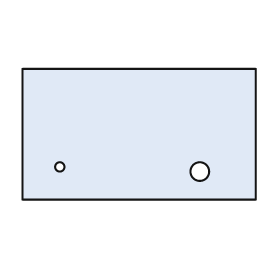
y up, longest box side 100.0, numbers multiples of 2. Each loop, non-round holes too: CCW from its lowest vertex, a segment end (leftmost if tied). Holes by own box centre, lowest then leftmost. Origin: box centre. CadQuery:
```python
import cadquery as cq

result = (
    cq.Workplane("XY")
    .moveTo(-50.0, -28.0)
    .lineTo(50.0, -28.0)
    .lineTo(50.0, 28.0)
    .lineTo(-50.0, 28.0)
    .close()
    .moveTo(26.0, -16.0)
    .circle(4.0)
    .moveTo(-34.0, -14.0)
    .circle(2.0)
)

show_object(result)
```